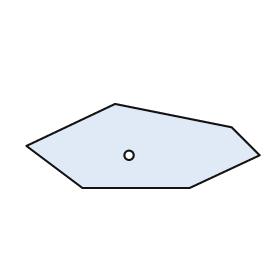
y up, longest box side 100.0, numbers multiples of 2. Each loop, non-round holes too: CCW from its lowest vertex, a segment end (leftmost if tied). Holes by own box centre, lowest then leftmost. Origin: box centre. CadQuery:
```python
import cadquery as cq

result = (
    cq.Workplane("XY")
    .moveTo(-26.0, -18.0)
    .lineTo(20.0, -18.0)
    .lineTo(50.0, -4.0)
    .lineTo(38.0, 8.0)
    .lineTo(-12.0, 18.0)
    .lineTo(-50.0, 0.0)
    .close()
    .moveTo(-6.0, -4.0)
    .circle(2.0)
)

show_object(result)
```